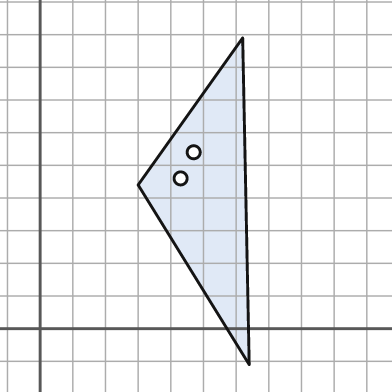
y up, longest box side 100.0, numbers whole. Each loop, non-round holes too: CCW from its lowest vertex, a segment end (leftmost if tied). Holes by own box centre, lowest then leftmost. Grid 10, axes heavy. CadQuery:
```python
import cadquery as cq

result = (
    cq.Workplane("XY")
    .moveTo(64.0, -11.0)
    .lineTo(62.0, 89.0)
    .lineTo(30.0, 44.0)
    .close()
    .moveTo(43.0, 46.0)
    .circle(2.0)
    .moveTo(47.0, 54.0)
    .circle(2.0)
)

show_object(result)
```